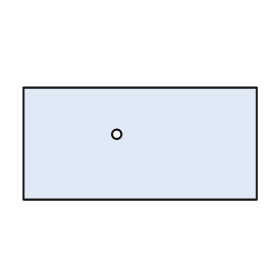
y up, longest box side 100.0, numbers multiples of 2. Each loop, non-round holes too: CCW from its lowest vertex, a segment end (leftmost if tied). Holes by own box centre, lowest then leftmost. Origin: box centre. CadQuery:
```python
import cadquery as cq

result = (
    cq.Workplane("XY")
    .moveTo(-50.0, -24.0)
    .lineTo(50.0, -24.0)
    .lineTo(50.0, 24.0)
    .lineTo(-50.0, 24.0)
    .close()
    .moveTo(-10.0, 4.0)
    .circle(2.0)
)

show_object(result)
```